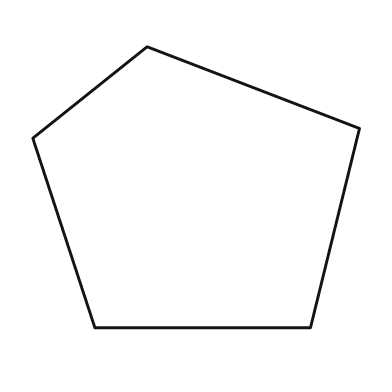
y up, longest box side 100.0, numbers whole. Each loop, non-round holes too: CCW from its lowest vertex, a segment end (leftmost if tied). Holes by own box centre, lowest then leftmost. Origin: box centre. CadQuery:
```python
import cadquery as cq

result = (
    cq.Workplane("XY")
    .moveTo(-31.0, -43.0)
    .lineTo(35.0, -43.0)
    .lineTo(50.0, 18.0)
    .lineTo(-15.0, 43.0)
    .lineTo(-50.0, 15.0)
    .close()
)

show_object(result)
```